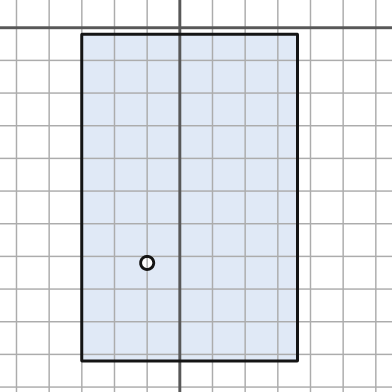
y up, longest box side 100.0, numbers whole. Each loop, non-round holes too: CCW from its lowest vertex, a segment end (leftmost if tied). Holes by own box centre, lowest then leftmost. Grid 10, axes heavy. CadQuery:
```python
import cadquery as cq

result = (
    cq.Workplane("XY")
    .moveTo(-30.0, -102.0)
    .lineTo(36.0, -102.0)
    .lineTo(36.0, -2.0)
    .lineTo(-30.0, -2.0)
    .close()
    .moveTo(-10.0, -72.0)
    .circle(2.0)
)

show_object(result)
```